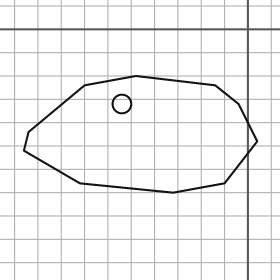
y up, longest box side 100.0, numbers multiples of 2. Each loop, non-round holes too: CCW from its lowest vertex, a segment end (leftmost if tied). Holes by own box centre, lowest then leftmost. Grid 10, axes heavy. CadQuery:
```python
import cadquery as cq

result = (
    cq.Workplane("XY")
    .moveTo(-32.0, -70.0)
    .lineTo(-10.0, -66.0)
    .lineTo(4.0, -48.0)
    .lineTo(-4.0, -32.0)
    .lineTo(-14.0, -24.0)
    .lineTo(-48.0, -20.0)
    .lineTo(-70.0, -24.0)
    .lineTo(-94.0, -44.0)
    .lineTo(-96.0, -52.0)
    .lineTo(-72.0, -66.0)
    .close()
    .moveTo(-54.0, -32.0)
    .circle(4.0)
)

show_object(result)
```